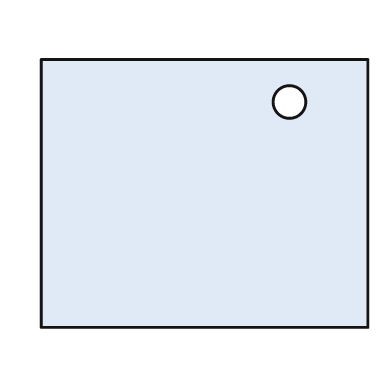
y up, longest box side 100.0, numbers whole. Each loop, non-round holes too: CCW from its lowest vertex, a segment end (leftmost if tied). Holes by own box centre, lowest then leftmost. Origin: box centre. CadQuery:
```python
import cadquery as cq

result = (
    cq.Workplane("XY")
    .moveTo(-50.0, -41.0)
    .lineTo(50.0, -41.0)
    .lineTo(50.0, 41.0)
    .lineTo(-50.0, 41.0)
    .close()
    .moveTo(26.0, 28.0)
    .circle(5.0)
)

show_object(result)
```